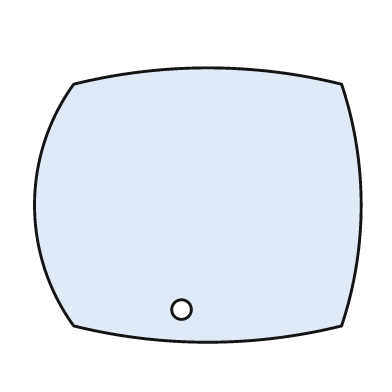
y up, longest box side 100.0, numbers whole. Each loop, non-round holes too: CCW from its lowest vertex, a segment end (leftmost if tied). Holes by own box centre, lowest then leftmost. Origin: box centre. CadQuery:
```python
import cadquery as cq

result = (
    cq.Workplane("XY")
    .moveTo(-38.0, -37.0)
    .threePointArc((3.0, -42.0), (44.0, -37.0))
    .threePointArc((50.0, 0.0), (44.0, 37.0))
    .threePointArc((3.0, 42.0), (-38.0, 37.0))
    .threePointArc((-50.0, 0.0), (-38.0, -37.0))
    .close()
    .moveTo(-5.0, -32.0)
    .circle(3.0)
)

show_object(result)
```